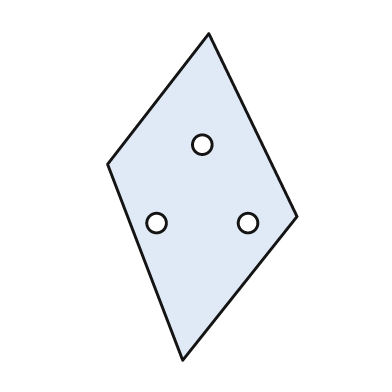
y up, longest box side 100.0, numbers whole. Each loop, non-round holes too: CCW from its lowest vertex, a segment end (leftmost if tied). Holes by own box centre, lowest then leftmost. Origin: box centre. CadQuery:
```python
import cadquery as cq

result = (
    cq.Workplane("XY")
    .moveTo(-6.0, -50.0)
    .lineTo(29.0, -6.0)
    .lineTo(2.0, 50.0)
    .lineTo(-29.0, 10.0)
    .close()
    .moveTo(-14.0, -8.0)
    .circle(3.0)
    .moveTo(14.0, -8.0)
    .circle(3.0)
    .moveTo(0.0, 16.0)
    .circle(3.0)
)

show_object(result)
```